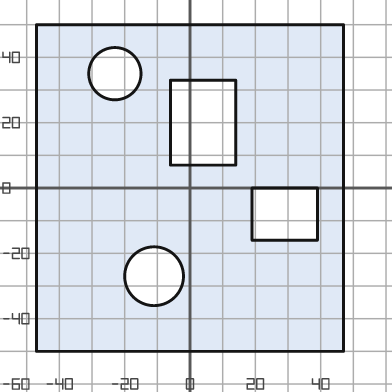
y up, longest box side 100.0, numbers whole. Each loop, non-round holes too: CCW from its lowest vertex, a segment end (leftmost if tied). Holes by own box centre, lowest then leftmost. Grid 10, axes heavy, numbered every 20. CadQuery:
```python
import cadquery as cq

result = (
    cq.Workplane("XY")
    .moveTo(-47.0, -50.0)
    .lineTo(47.0, -50.0)
    .lineTo(47.0, 50.0)
    .lineTo(-47.0, 50.0)
    .close()
    .moveTo(-11.0, -27.0)
    .circle(9.0)
    .moveTo(19.0, -16.0)
    .lineTo(39.0, -16.0)
    .lineTo(39.0, 0.0)
    .lineTo(19.0, 0.0)
    .close()
    .moveTo(-6.0, 7.0)
    .lineTo(14.0, 7.0)
    .lineTo(14.0, 33.0)
    .lineTo(-6.0, 33.0)
    .close()
    .moveTo(-23.0, 35.0)
    .circle(8.0)
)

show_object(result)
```